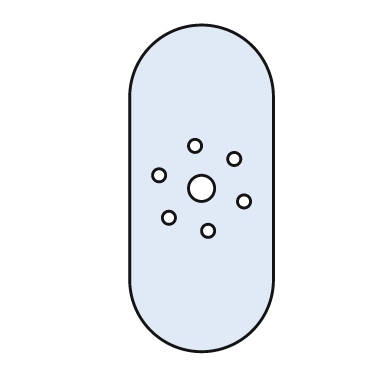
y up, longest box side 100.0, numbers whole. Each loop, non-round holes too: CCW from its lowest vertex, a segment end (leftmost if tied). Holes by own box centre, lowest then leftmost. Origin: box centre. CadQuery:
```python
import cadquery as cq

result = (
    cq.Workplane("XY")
    .moveTo(-22.0, -28.0)
    .threePointArc((0.0, -50.0), (22.0, -28.0))
    .lineTo(22.0, 28.0)
    .threePointArc((0.0, 50.0), (-22.0, 28.0))
    .close()
    .moveTo(2.0, -13.0)
    .circle(2.0)
    .moveTo(-10.0, -9.0)
    .circle(2.0)
    .moveTo(13.0, -4.0)
    .circle(2.0)
    .moveTo(0.0, 0.0)
    .circle(4.0)
    .moveTo(-13.0, 4.0)
    .circle(2.0)
    .moveTo(10.0, 9.0)
    .circle(2.0)
    .moveTo(-2.0, 13.0)
    .circle(2.0)
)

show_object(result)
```